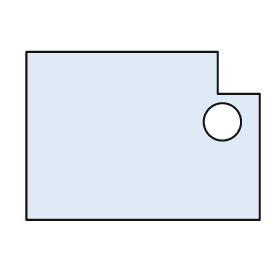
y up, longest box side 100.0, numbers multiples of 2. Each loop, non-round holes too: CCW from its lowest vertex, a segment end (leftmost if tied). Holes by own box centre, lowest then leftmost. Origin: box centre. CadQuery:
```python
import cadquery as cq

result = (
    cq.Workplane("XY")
    .moveTo(-50.0, -36.0)
    .lineTo(50.0, -36.0)
    .lineTo(50.0, 18.0)
    .lineTo(32.0, 18.0)
    .lineTo(32.0, 36.0)
    .lineTo(-50.0, 36.0)
    .close()
    .moveTo(34.0, 6.0)
    .circle(8.0)
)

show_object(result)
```